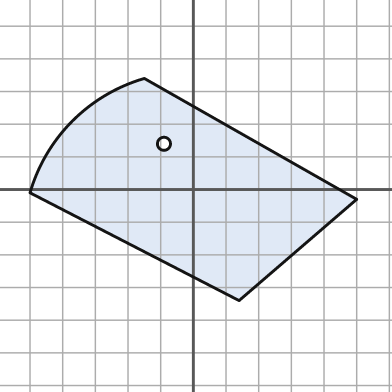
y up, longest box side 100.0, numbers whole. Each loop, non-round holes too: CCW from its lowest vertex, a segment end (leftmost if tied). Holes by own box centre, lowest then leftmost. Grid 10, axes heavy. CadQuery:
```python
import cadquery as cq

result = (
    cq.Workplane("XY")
    .moveTo(14.0, -34.0)
    .lineTo(50.0, -3.0)
    .lineTo(-15.0, 34.0)
    .threePointArc((-37.0, 21.0), (-50.0, -1.0))
    .close()
    .moveTo(-9.0, 14.0)
    .circle(2.0)
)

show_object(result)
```